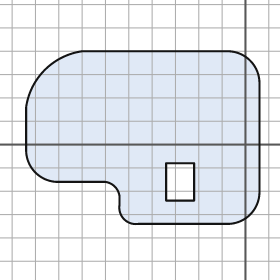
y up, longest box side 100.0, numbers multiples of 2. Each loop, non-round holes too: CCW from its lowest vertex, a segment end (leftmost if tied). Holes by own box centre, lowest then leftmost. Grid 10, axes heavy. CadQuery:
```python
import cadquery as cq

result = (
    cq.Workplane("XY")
    .moveTo(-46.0, -34.0)
    .lineTo(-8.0, -34.0)
    .threePointArc((2.0, -30.0), (6.0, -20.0))
    .lineTo(6.0, 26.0)
    .threePointArc((2.0, 36.0), (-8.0, 40.0))
    .lineTo(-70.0, 40.0)
    .threePointArc((-86.0, 32.0), (-94.0, 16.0))
    .lineTo(-94.0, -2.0)
    .threePointArc((-90.0, -12.0), (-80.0, -16.0))
    .lineTo(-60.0, -16.0)
    .threePointArc((-56.0, -18.0), (-54.0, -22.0))
    .lineTo(-54.0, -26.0)
    .threePointArc((-52.0, -32.0), (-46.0, -34.0))
    .close()
    .moveTo(-34.0, -24.0)
    .lineTo(-22.0, -24.0)
    .lineTo(-22.0, -8.0)
    .lineTo(-34.0, -8.0)
    .close()
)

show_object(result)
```